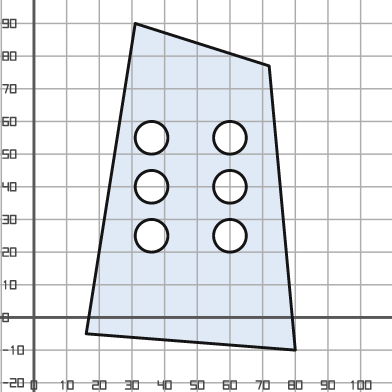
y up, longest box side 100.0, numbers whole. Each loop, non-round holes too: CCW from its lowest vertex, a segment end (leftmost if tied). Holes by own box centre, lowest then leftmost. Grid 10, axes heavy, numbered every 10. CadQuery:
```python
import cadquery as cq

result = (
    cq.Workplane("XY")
    .moveTo(80.0, -10.0)
    .lineTo(72.0, 77.0)
    .lineTo(31.0, 90.0)
    .lineTo(16.0, -5.0)
    .close()
    .moveTo(36.0, 25.0)
    .circle(5.0)
    .moveTo(60.0, 25.0)
    .circle(5.0)
    .moveTo(36.0, 40.0)
    .circle(5.0)
    .moveTo(60.0, 40.0)
    .circle(5.0)
    .moveTo(36.0, 55.0)
    .circle(5.0)
    .moveTo(60.0, 55.0)
    .circle(5.0)
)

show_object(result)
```